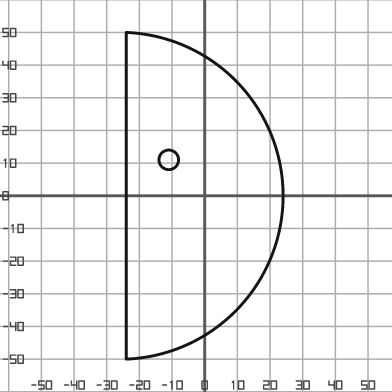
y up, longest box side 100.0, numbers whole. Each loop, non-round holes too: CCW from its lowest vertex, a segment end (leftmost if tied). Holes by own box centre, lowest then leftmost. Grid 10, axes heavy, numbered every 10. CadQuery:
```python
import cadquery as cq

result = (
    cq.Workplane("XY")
    .moveTo(-24.0, -50.0)
    .threePointArc((24.0, 0.0), (-24.0, 50.0))
    .close()
    .moveTo(-11.0, 11.0)
    .circle(3.0)
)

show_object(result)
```